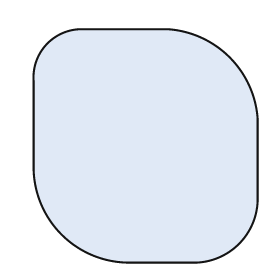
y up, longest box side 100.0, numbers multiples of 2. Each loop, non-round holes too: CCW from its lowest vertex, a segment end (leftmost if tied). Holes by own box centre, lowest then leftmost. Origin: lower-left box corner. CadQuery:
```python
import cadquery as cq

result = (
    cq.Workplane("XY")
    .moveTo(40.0, 0.0)
    .lineTo(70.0, 0.0)
    .threePointArc((88.0, 8.0), (96.0, 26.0))
    .lineTo(96.0, 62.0)
    .threePointArc((84.0, 88.0), (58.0, 100.0))
    .lineTo(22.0, 100.0)
    .threePointArc((6.0, 94.0), (0.0, 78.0))
    .lineTo(0.0, 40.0)
    .threePointArc((12.0, 12.0), (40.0, 0.0))
    .close()
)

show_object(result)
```